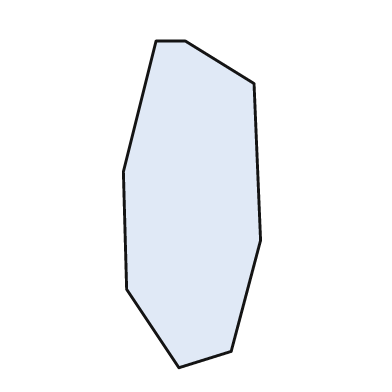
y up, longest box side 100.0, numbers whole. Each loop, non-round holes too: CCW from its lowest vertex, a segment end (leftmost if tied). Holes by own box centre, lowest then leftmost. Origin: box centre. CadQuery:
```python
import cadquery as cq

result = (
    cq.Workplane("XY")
    .moveTo(-4.0, -50.0)
    .lineTo(12.0, -45.0)
    .lineTo(21.0, -11.0)
    .lineTo(19.0, 37.0)
    .lineTo(-2.0, 50.0)
    .lineTo(-11.0, 50.0)
    .lineTo(-21.0, 10.0)
    .lineTo(-20.0, -26.0)
    .close()
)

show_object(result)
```